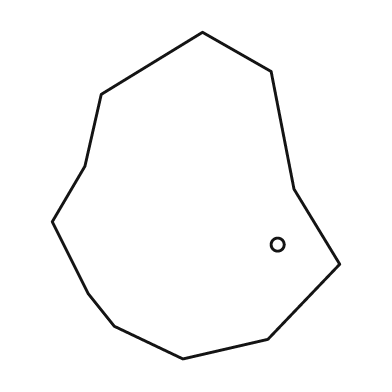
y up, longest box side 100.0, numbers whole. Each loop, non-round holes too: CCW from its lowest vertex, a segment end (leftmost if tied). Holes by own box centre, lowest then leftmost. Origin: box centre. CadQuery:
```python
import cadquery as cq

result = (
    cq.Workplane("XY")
    .moveTo(-4.0, -50.0)
    .lineTo(22.0, -44.0)
    .lineTo(44.0, -21.0)
    .lineTo(30.0, 2.0)
    .lineTo(23.0, 38.0)
    .lineTo(2.0, 50.0)
    .lineTo(-29.0, 31.0)
    .lineTo(-34.0, 9.0)
    .lineTo(-44.0, -8.0)
    .lineTo(-33.0, -30.0)
    .lineTo(-25.0, -40.0)
    .close()
    .moveTo(25.0, -15.0)
    .circle(2.0)
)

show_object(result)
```